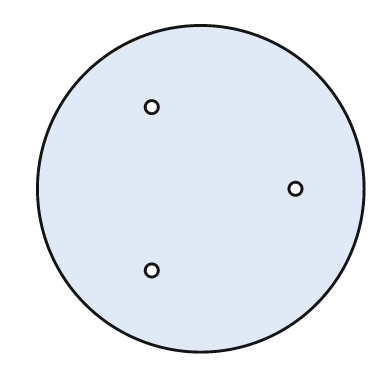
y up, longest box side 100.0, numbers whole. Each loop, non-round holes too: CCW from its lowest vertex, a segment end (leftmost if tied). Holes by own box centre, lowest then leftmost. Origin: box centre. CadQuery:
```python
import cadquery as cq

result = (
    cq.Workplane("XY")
    .moveTo(0.0, 0.0)
    .circle(50.0)
    .moveTo(-15.0, -25.0)
    .circle(2.0)
    .moveTo(29.0, 0.0)
    .circle(2.0)
    .moveTo(-15.0, 25.0)
    .circle(2.0)
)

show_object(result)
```